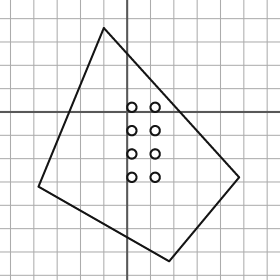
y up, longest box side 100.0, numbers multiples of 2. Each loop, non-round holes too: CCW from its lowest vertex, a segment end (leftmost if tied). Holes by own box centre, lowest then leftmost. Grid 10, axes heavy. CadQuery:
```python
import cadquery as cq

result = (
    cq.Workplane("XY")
    .moveTo(18.0, -64.0)
    .lineTo(48.0, -28.0)
    .lineTo(-10.0, 36.0)
    .lineTo(-38.0, -32.0)
    .close()
    .moveTo(2.0, -28.0)
    .circle(2.0)
    .moveTo(12.0, -28.0)
    .circle(2.0)
    .moveTo(2.0, -18.0)
    .circle(2.0)
    .moveTo(12.0, -18.0)
    .circle(2.0)
    .moveTo(2.0, -8.0)
    .circle(2.0)
    .moveTo(12.0, -8.0)
    .circle(2.0)
    .moveTo(2.0, 2.0)
    .circle(2.0)
    .moveTo(12.0, 2.0)
    .circle(2.0)
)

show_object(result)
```